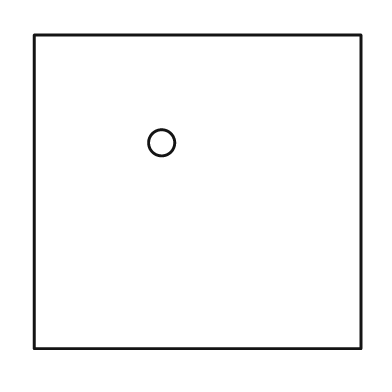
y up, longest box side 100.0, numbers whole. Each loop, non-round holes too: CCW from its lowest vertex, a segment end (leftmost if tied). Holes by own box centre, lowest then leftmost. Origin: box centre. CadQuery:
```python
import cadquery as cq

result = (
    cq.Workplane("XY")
    .moveTo(-50.0, -48.0)
    .lineTo(50.0, -48.0)
    .lineTo(50.0, 48.0)
    .lineTo(-50.0, 48.0)
    .close()
    .moveTo(-11.0, 15.0)
    .circle(4.0)
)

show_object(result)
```